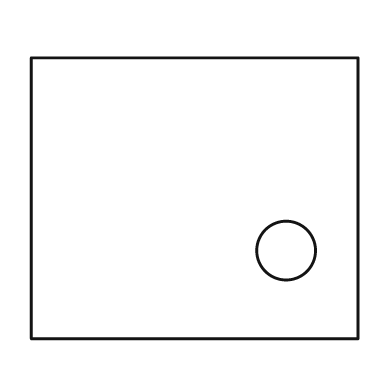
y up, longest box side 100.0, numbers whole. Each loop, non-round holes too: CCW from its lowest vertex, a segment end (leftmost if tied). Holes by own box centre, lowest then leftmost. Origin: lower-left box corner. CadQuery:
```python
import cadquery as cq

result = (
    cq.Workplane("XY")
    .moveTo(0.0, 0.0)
    .lineTo(100.0, 0.0)
    .lineTo(100.0, 86.0)
    .lineTo(0.0, 86.0)
    .close()
    .moveTo(78.0, 27.0)
    .circle(9.0)
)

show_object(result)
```